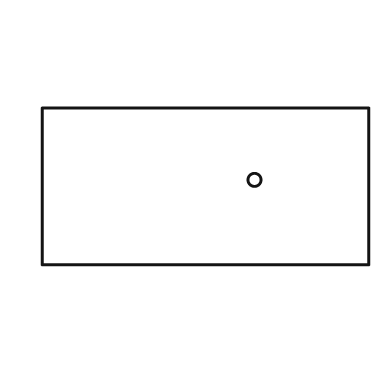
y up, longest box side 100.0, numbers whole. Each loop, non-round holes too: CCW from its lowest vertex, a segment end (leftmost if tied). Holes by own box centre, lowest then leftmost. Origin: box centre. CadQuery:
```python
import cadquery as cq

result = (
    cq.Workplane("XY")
    .moveTo(-50.0, -24.0)
    .lineTo(50.0, -24.0)
    .lineTo(50.0, 24.0)
    .lineTo(-50.0, 24.0)
    .close()
    .moveTo(15.0, 2.0)
    .circle(2.0)
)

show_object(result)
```